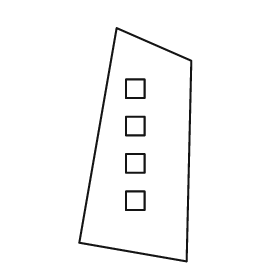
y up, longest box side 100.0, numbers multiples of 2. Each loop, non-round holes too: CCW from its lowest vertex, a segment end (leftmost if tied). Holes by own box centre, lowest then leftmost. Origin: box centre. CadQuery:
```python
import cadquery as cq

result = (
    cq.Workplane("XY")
    .moveTo(22.0, -50.0)
    .lineTo(24.0, 36.0)
    .lineTo(-8.0, 50.0)
    .lineTo(-24.0, -42.0)
    .close()
    .moveTo(-4.0, -28.0)
    .lineTo(4.0, -28.0)
    .lineTo(4.0, -20.0)
    .lineTo(-4.0, -20.0)
    .close()
    .moveTo(-4.0, -12.0)
    .lineTo(4.0, -12.0)
    .lineTo(4.0, -4.0)
    .lineTo(-4.0, -4.0)
    .close()
    .moveTo(-4.0, 4.0)
    .lineTo(4.0, 4.0)
    .lineTo(4.0, 12.0)
    .lineTo(-4.0, 12.0)
    .close()
    .moveTo(-4.0, 20.0)
    .lineTo(4.0, 20.0)
    .lineTo(4.0, 28.0)
    .lineTo(-4.0, 28.0)
    .close()
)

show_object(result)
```